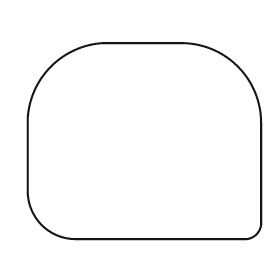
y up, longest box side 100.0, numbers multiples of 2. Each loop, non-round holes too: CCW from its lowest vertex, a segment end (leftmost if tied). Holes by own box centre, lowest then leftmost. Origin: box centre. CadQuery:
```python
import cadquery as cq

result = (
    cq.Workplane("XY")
    .moveTo(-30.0, -42.0)
    .lineTo(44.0, -42.0)
    .threePointArc((48.0, -40.0), (50.0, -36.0))
    .lineTo(50.0, 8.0)
    .threePointArc((40.0, 32.0), (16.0, 42.0))
    .lineTo(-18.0, 42.0)
    .threePointArc((-40.0, 32.0), (-50.0, 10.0))
    .lineTo(-50.0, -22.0)
    .threePointArc((-44.0, -36.0), (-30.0, -42.0))
    .close()
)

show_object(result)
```